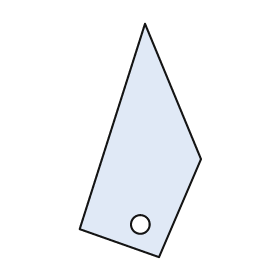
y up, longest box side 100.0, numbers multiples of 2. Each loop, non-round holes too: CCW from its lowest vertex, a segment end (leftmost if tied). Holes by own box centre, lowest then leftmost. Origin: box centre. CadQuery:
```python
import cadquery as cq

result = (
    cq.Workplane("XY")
    .moveTo(8.0, -50.0)
    .lineTo(26.0, -8.0)
    .lineTo(2.0, 50.0)
    .lineTo(-26.0, -38.0)
    .close()
    .moveTo(0.0, -36.0)
    .circle(4.0)
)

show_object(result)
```